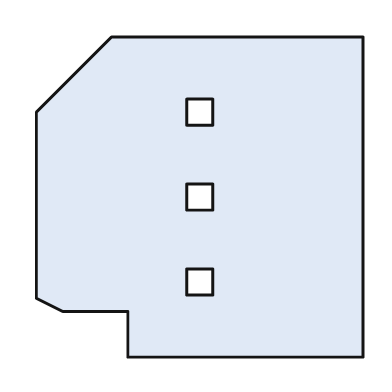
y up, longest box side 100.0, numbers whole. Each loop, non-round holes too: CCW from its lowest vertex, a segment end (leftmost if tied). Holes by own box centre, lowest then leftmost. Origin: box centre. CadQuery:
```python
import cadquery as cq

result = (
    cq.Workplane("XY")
    .moveTo(-22.0, -49.0)
    .lineTo(50.0, -49.0)
    .lineTo(50.0, 49.0)
    .lineTo(-27.0, 49.0)
    .lineTo(-50.0, 26.0)
    .lineTo(-50.0, -31.0)
    .lineTo(-42.0, -35.0)
    .lineTo(-22.0, -35.0)
    .close()
    .moveTo(-4.0, -30.0)
    .lineTo(4.0, -30.0)
    .lineTo(4.0, -22.0)
    .lineTo(-4.0, -22.0)
    .close()
    .moveTo(-4.0, -4.0)
    .lineTo(4.0, -4.0)
    .lineTo(4.0, 4.0)
    .lineTo(-4.0, 4.0)
    .close()
    .moveTo(-4.0, 22.0)
    .lineTo(4.0, 22.0)
    .lineTo(4.0, 30.0)
    .lineTo(-4.0, 30.0)
    .close()
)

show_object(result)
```